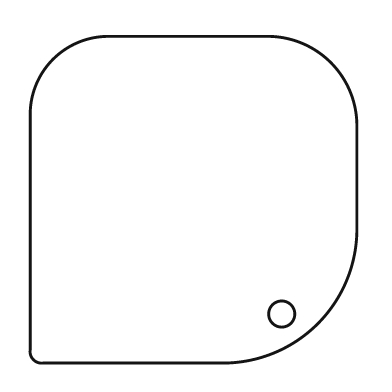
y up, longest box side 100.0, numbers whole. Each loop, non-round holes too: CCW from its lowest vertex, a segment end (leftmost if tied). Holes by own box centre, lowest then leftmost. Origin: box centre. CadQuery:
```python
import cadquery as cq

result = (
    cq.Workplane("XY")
    .moveTo(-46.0, -50.0)
    .lineTo(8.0, -50.0)
    .threePointArc((38.0, -38.0), (50.0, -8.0))
    .lineTo(50.0, 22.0)
    .threePointArc((42.0, 42.0), (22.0, 50.0))
    .lineTo(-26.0, 50.0)
    .threePointArc((-43.0, 43.0), (-50.0, 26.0))
    .lineTo(-50.0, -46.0)
    .threePointArc((-49.0, -49.0), (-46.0, -50.0))
    .close()
    .moveTo(27.0, -35.0)
    .circle(4.0)
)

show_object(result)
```